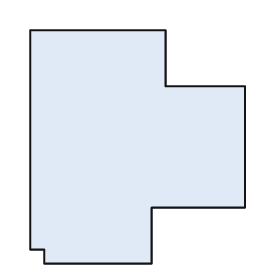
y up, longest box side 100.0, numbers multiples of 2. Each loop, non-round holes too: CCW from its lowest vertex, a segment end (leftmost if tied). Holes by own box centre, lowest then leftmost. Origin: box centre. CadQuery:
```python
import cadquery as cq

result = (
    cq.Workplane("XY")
    .moveTo(-40.0, -50.0)
    .lineTo(6.0, -50.0)
    .lineTo(6.0, -26.0)
    .lineTo(46.0, -26.0)
    .lineTo(46.0, 26.0)
    .lineTo(12.0, 26.0)
    .lineTo(12.0, 50.0)
    .lineTo(-46.0, 50.0)
    .lineTo(-46.0, -44.0)
    .lineTo(-40.0, -44.0)
    .close()
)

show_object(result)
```